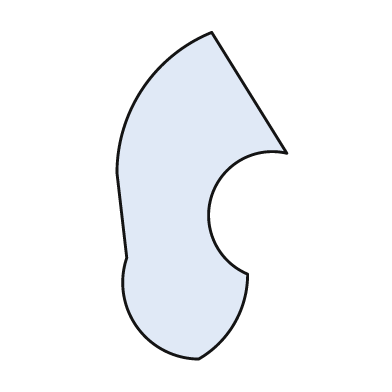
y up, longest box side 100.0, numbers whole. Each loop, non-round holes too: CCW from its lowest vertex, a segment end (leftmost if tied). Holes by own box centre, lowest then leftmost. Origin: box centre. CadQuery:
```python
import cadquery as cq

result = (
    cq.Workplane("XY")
    .moveTo(-1.0, -50.0)
    .threePointArc((10.0, -39.0), (14.0, -24.0))
    .threePointArc((3.0, 0.0), (26.0, 13.0))
    .lineTo(3.0, 50.0)
    .threePointArc((-18.0, 33.0), (-26.0, 7.0))
    .lineTo(-23.0, -19.0)
    .threePointArc((-20.0, -40.0), (-1.0, -50.0))
    .close()
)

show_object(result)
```